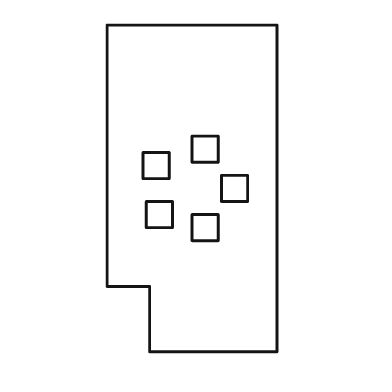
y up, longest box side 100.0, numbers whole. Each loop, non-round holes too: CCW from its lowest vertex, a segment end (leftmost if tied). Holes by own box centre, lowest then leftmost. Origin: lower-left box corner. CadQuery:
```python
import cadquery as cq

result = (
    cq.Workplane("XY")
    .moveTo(13.0, 0.0)
    .lineTo(52.0, 0.0)
    .lineTo(52.0, 100.0)
    .lineTo(0.0, 100.0)
    .lineTo(0.0, 20.0)
    .lineTo(13.0, 20.0)
    .close()
    .moveTo(26.0, 34.0)
    .lineTo(34.0, 34.0)
    .lineTo(34.0, 42.0)
    .lineTo(26.0, 42.0)
    .close()
    .moveTo(12.0, 38.0)
    .lineTo(20.0, 38.0)
    .lineTo(20.0, 46.0)
    .lineTo(12.0, 46.0)
    .close()
    .moveTo(35.0, 46.0)
    .lineTo(43.0, 46.0)
    .lineTo(43.0, 54.0)
    .lineTo(35.0, 54.0)
    .close()
    .moveTo(11.0, 53.0)
    .lineTo(19.0, 53.0)
    .lineTo(19.0, 61.0)
    .lineTo(11.0, 61.0)
    .close()
    .moveTo(26.0, 58.0)
    .lineTo(34.0, 58.0)
    .lineTo(34.0, 66.0)
    .lineTo(26.0, 66.0)
    .close()
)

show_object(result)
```